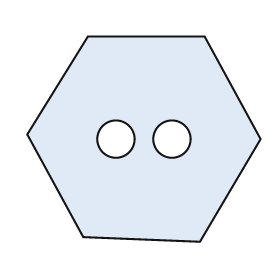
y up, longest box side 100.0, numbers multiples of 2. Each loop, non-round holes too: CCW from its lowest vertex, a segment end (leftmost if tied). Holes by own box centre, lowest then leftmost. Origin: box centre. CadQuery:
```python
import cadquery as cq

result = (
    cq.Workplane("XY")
    .moveTo(24.0, -44.0)
    .lineTo(50.0, 0.0)
    .lineTo(26.0, 44.0)
    .lineTo(-24.0, 44.0)
    .lineTo(-50.0, 2.0)
    .lineTo(-26.0, -42.0)
    .close()
    .moveTo(-12.0, 0.0)
    .circle(8.0)
    .moveTo(12.0, 0.0)
    .circle(8.0)
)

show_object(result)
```